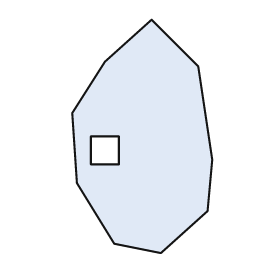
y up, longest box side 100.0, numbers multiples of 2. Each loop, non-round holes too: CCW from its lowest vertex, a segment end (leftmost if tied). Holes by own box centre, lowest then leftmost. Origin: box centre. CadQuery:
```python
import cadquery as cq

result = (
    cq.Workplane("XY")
    .moveTo(8.0, -50.0)
    .lineTo(28.0, -32.0)
    .lineTo(30.0, -10.0)
    .lineTo(24.0, 30.0)
    .lineTo(4.0, 50.0)
    .lineTo(-16.0, 32.0)
    .lineTo(-30.0, 10.0)
    .lineTo(-28.0, -20.0)
    .lineTo(-12.0, -46.0)
    .close()
    .moveTo(-22.0, -12.0)
    .lineTo(-10.0, -12.0)
    .lineTo(-10.0, 0.0)
    .lineTo(-22.0, 0.0)
    .close()
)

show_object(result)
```